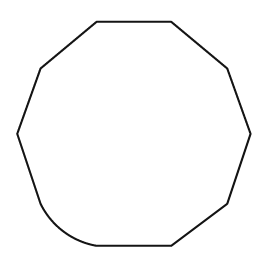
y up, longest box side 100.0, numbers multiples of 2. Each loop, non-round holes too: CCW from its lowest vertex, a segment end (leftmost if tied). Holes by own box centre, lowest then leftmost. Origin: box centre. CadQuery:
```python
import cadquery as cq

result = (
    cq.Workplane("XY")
    .moveTo(-16.0, -48.0)
    .lineTo(16.0, -48.0)
    .lineTo(40.0, -30.0)
    .lineTo(50.0, 0.0)
    .lineTo(40.0, 28.0)
    .lineTo(16.0, 48.0)
    .lineTo(-16.0, 48.0)
    .lineTo(-40.0, 28.0)
    .lineTo(-50.0, 0.0)
    .lineTo(-40.0, -30.0)
    .threePointArc((-30.0, -42.0), (-16.0, -48.0))
    .close()
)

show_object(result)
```